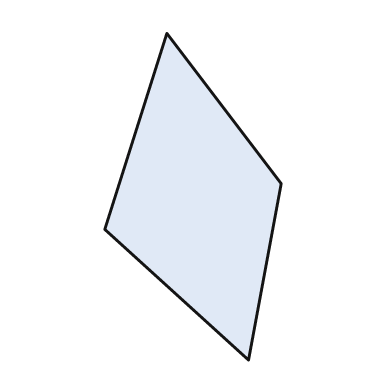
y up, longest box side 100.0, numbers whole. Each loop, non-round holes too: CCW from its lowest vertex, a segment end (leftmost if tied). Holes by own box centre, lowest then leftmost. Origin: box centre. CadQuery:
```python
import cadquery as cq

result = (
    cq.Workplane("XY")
    .moveTo(17.0, -50.0)
    .lineTo(27.0, 4.0)
    .lineTo(-8.0, 50.0)
    .lineTo(-27.0, -10.0)
    .close()
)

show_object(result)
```